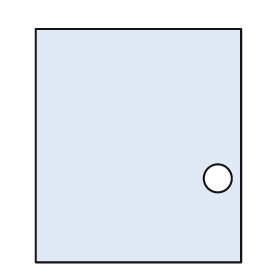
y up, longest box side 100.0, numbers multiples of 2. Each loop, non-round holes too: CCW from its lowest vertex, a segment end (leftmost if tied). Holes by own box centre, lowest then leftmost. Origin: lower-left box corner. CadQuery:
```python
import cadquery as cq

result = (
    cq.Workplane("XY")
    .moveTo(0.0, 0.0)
    .lineTo(88.0, 0.0)
    .lineTo(88.0, 100.0)
    .lineTo(0.0, 100.0)
    .close()
    .moveTo(78.0, 36.0)
    .circle(6.0)
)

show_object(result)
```